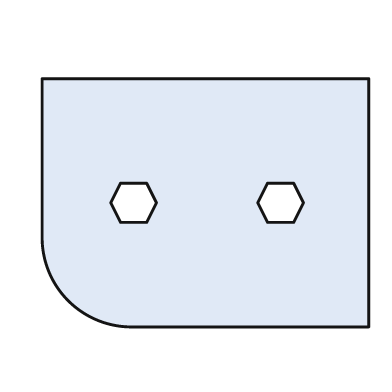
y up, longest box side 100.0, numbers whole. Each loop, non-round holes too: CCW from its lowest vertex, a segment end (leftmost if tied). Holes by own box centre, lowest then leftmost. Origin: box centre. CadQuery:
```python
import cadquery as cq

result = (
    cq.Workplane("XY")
    .moveTo(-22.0, -38.0)
    .lineTo(50.0, -38.0)
    .lineTo(50.0, 38.0)
    .lineTo(-50.0, 38.0)
    .lineTo(-50.0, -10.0)
    .threePointArc((-42.0, -30.0), (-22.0, -38.0))
    .close()
    .moveTo(-26.0, -6.0)
    .lineTo(-18.0, -6.0)
    .lineTo(-15.0, 0.0)
    .lineTo(-18.0, 6.0)
    .lineTo(-26.0, 6.0)
    .lineTo(-29.0, 0.0)
    .close()
    .moveTo(19.0, -6.0)
    .lineTo(27.0, -6.0)
    .lineTo(30.0, 0.0)
    .lineTo(27.0, 6.0)
    .lineTo(19.0, 6.0)
    .lineTo(16.0, 0.0)
    .close()
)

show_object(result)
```